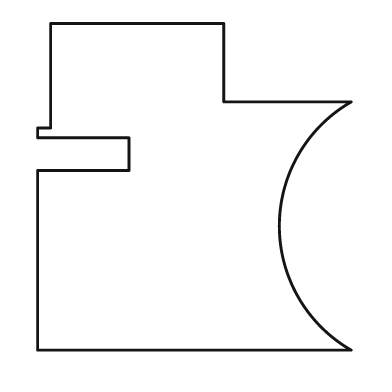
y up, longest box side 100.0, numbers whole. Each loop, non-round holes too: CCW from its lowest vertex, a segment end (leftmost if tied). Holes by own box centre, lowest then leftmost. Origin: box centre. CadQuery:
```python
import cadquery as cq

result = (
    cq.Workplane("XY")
    .moveTo(-48.0, -50.0)
    .lineTo(48.0, -50.0)
    .threePointArc((26.0, -12.0), (48.0, 26.0))
    .lineTo(9.0, 26.0)
    .lineTo(9.0, 50.0)
    .lineTo(-44.0, 50.0)
    .lineTo(-44.0, 18.0)
    .lineTo(-48.0, 18.0)
    .lineTo(-48.0, 15.0)
    .lineTo(-20.0, 15.0)
    .lineTo(-20.0, 5.0)
    .lineTo(-48.0, 5.0)
    .close()
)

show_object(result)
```